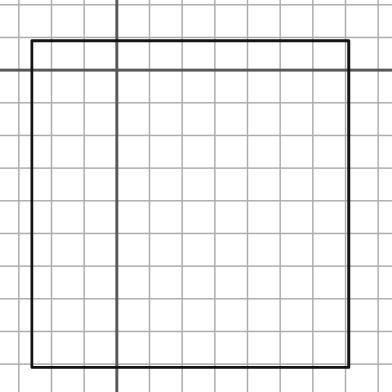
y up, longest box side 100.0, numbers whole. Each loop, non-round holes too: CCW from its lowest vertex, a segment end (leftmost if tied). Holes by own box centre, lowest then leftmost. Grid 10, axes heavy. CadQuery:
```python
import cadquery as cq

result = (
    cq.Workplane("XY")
    .moveTo(-26.0, -91.0)
    .lineTo(71.0, -91.0)
    .lineTo(71.0, 9.0)
    .lineTo(-26.0, 9.0)
    .close()
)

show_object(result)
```